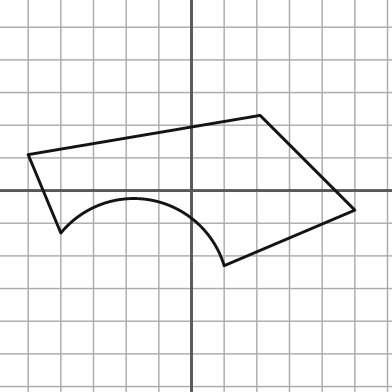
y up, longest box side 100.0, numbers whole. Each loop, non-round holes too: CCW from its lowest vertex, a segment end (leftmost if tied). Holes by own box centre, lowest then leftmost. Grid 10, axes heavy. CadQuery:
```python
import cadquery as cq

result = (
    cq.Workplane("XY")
    .moveTo(10.0, -23.0)
    .lineTo(50.0, -6.0)
    .lineTo(21.0, 23.0)
    .lineTo(-50.0, 11.0)
    .lineTo(-40.0, -13.0)
    .threePointArc((-12.0, -3.0), (10.0, -23.0))
    .close()
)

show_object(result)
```